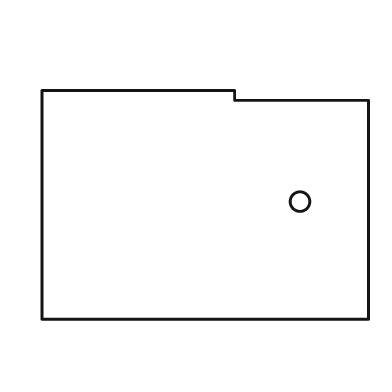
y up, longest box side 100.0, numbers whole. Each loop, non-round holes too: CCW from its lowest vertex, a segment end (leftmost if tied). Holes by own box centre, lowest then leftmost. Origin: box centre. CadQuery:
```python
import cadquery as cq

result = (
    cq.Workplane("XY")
    .moveTo(-50.0, -35.0)
    .lineTo(50.0, -35.0)
    .lineTo(50.0, 32.0)
    .lineTo(9.0, 32.0)
    .lineTo(9.0, 35.0)
    .lineTo(-50.0, 35.0)
    .close()
    .moveTo(29.0, 1.0)
    .circle(3.0)
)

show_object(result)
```